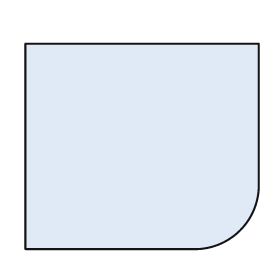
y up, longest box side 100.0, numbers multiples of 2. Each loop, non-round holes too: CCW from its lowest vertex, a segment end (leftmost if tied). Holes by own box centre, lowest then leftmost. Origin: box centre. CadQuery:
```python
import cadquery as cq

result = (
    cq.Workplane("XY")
    .moveTo(-50.0, -44.0)
    .lineTo(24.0, -44.0)
    .threePointArc((42.0, -36.0), (50.0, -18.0))
    .lineTo(50.0, 44.0)
    .lineTo(-50.0, 44.0)
    .close()
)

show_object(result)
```